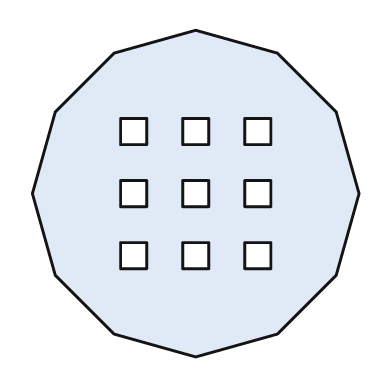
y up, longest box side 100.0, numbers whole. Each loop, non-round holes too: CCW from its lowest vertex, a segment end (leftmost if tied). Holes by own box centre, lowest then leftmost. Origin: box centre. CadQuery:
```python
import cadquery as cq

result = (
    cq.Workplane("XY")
    .moveTo(0.0, -50.0)
    .lineTo(25.0, -43.0)
    .lineTo(43.0, -25.0)
    .lineTo(50.0, 0.0)
    .lineTo(43.0, 25.0)
    .lineTo(25.0, 43.0)
    .lineTo(0.0, 50.0)
    .lineTo(-25.0, 43.0)
    .lineTo(-43.0, 25.0)
    .lineTo(-50.0, 0.0)
    .lineTo(-43.0, -25.0)
    .lineTo(-25.0, -43.0)
    .close()
    .moveTo(-23.0, -23.0)
    .lineTo(-15.0, -23.0)
    .lineTo(-15.0, -15.0)
    .lineTo(-23.0, -15.0)
    .close()
    .moveTo(-4.0, -23.0)
    .lineTo(4.0, -23.0)
    .lineTo(4.0, -15.0)
    .lineTo(-4.0, -15.0)
    .close()
    .moveTo(15.0, -23.0)
    .lineTo(23.0, -23.0)
    .lineTo(23.0, -15.0)
    .lineTo(15.0, -15.0)
    .close()
    .moveTo(-23.0, -4.0)
    .lineTo(-15.0, -4.0)
    .lineTo(-15.0, 4.0)
    .lineTo(-23.0, 4.0)
    .close()
    .moveTo(-4.0, -4.0)
    .lineTo(4.0, -4.0)
    .lineTo(4.0, 4.0)
    .lineTo(-4.0, 4.0)
    .close()
    .moveTo(15.0, -4.0)
    .lineTo(23.0, -4.0)
    .lineTo(23.0, 4.0)
    .lineTo(15.0, 4.0)
    .close()
    .moveTo(-23.0, 15.0)
    .lineTo(-15.0, 15.0)
    .lineTo(-15.0, 23.0)
    .lineTo(-23.0, 23.0)
    .close()
    .moveTo(-4.0, 15.0)
    .lineTo(4.0, 15.0)
    .lineTo(4.0, 23.0)
    .lineTo(-4.0, 23.0)
    .close()
    .moveTo(15.0, 15.0)
    .lineTo(23.0, 15.0)
    .lineTo(23.0, 23.0)
    .lineTo(15.0, 23.0)
    .close()
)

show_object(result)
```